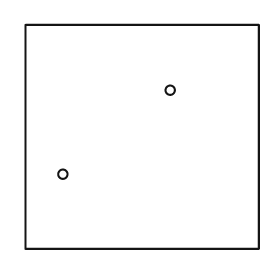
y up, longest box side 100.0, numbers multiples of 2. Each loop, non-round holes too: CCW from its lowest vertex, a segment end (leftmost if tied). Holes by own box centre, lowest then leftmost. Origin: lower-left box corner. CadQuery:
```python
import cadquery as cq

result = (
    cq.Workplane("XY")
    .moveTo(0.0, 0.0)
    .lineTo(100.0, 0.0)
    .lineTo(100.0, 96.0)
    .lineTo(0.0, 96.0)
    .close()
    .moveTo(16.0, 32.0)
    .circle(2.0)
    .moveTo(62.0, 68.0)
    .circle(2.0)
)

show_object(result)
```